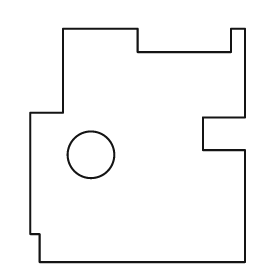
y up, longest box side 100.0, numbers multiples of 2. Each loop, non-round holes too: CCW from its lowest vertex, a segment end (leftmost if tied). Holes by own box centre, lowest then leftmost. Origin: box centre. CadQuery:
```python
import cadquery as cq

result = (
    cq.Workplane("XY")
    .moveTo(-42.0, -50.0)
    .lineTo(46.0, -50.0)
    .lineTo(46.0, -2.0)
    .lineTo(28.0, -2.0)
    .lineTo(28.0, 12.0)
    .lineTo(46.0, 12.0)
    .lineTo(46.0, 50.0)
    .lineTo(40.0, 50.0)
    .lineTo(40.0, 40.0)
    .lineTo(0.0, 40.0)
    .lineTo(0.0, 50.0)
    .lineTo(-32.0, 50.0)
    .lineTo(-32.0, 14.0)
    .lineTo(-46.0, 14.0)
    .lineTo(-46.0, -38.0)
    .lineTo(-42.0, -38.0)
    .close()
    .moveTo(-20.0, -4.0)
    .circle(10.0)
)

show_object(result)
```